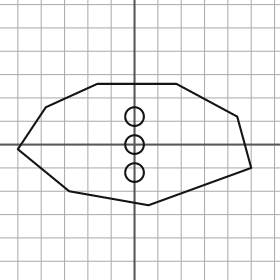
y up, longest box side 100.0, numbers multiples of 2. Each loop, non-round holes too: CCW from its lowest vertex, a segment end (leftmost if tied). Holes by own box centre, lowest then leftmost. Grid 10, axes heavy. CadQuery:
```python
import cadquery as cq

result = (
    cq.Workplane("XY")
    .moveTo(6.0, -26.0)
    .lineTo(50.0, -10.0)
    .lineTo(44.0, 12.0)
    .lineTo(18.0, 26.0)
    .lineTo(-16.0, 26.0)
    .lineTo(-38.0, 16.0)
    .lineTo(-50.0, -2.0)
    .lineTo(-28.0, -20.0)
    .close()
    .moveTo(0.0, -12.0)
    .circle(4.0)
    .moveTo(0.0, 0.0)
    .circle(4.0)
    .moveTo(0.0, 12.0)
    .circle(4.0)
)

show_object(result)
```